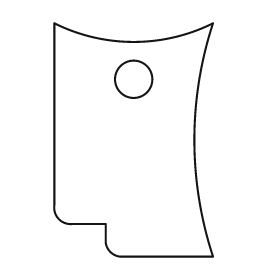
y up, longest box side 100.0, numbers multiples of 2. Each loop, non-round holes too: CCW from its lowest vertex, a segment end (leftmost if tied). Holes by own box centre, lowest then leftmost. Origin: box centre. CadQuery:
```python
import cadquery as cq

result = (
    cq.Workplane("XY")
    .moveTo(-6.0, -50.0)
    .lineTo(34.0, -50.0)
    .threePointArc((26.0, 0.0), (34.0, 50.0))
    .threePointArc((0.0, 42.0), (-34.0, 50.0))
    .lineTo(-34.0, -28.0)
    .threePointArc((-32.0, -34.0), (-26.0, -36.0))
    .lineTo(-12.0, -36.0)
    .lineTo(-12.0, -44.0)
    .threePointArc((-10.0, -48.0), (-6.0, -50.0))
    .close()
    .moveTo(0.0, 26.0)
    .circle(8.0)
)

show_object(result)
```